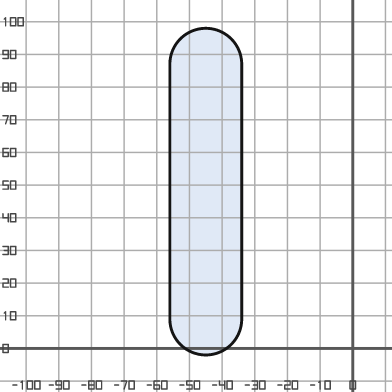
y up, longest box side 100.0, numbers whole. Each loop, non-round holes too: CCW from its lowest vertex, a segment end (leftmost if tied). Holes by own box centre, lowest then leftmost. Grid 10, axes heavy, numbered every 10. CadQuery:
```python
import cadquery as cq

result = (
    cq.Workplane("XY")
    .moveTo(-56.0, 9.0)
    .threePointArc((-45.0, -2.0), (-34.0, 9.0))
    .lineTo(-34.0, 87.0)
    .threePointArc((-45.0, 98.0), (-56.0, 87.0))
    .close()
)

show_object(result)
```